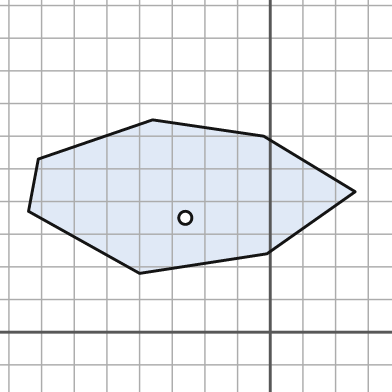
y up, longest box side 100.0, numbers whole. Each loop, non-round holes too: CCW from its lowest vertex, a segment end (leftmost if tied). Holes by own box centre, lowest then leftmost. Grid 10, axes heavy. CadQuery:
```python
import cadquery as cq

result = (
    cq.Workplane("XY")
    .moveTo(-40.0, 18.0)
    .lineTo(-1.0, 24.0)
    .lineTo(26.0, 43.0)
    .lineTo(-2.0, 60.0)
    .lineTo(-36.0, 65.0)
    .lineTo(-71.0, 53.0)
    .lineTo(-74.0, 37.0)
    .close()
    .moveTo(-26.0, 35.0)
    .circle(2.0)
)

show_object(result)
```